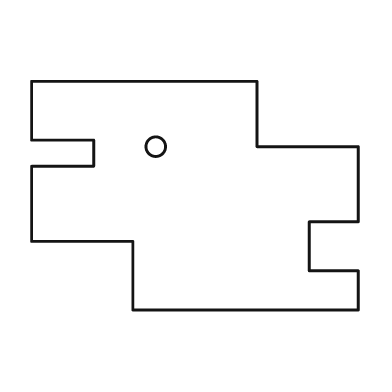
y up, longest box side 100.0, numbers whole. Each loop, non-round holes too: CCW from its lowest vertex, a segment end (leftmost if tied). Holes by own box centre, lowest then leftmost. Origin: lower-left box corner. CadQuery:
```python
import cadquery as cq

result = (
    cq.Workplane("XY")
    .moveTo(31.0, 0.0)
    .lineTo(100.0, 0.0)
    .lineTo(100.0, 12.0)
    .lineTo(85.0, 12.0)
    .lineTo(85.0, 27.0)
    .lineTo(100.0, 27.0)
    .lineTo(100.0, 50.0)
    .lineTo(69.0, 50.0)
    .lineTo(69.0, 70.0)
    .lineTo(0.0, 70.0)
    .lineTo(0.0, 52.0)
    .lineTo(19.0, 52.0)
    .lineTo(19.0, 44.0)
    .lineTo(0.0, 44.0)
    .lineTo(0.0, 21.0)
    .lineTo(31.0, 21.0)
    .close()
    .moveTo(38.0, 50.0)
    .circle(3.0)
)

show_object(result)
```